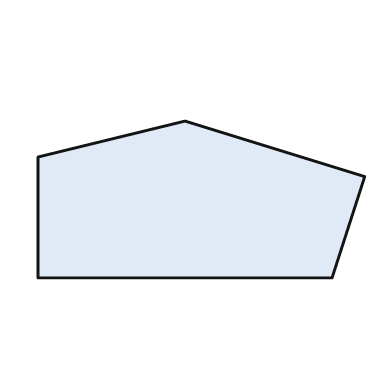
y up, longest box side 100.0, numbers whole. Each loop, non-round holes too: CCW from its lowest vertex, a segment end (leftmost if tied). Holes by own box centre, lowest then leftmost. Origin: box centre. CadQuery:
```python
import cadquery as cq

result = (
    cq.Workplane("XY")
    .moveTo(-50.0, -24.0)
    .lineTo(40.0, -24.0)
    .lineTo(50.0, 7.0)
    .lineTo(-5.0, 24.0)
    .lineTo(-50.0, 13.0)
    .close()
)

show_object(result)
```